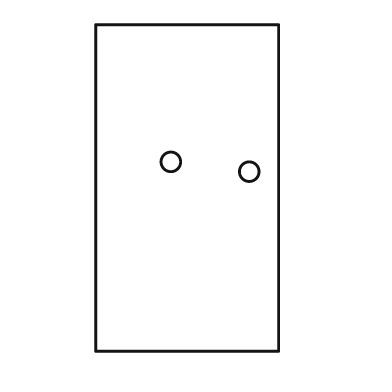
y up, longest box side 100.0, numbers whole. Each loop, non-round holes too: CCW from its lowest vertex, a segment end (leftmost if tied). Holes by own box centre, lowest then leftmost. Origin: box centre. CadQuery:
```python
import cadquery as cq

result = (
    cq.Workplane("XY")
    .moveTo(-28.0, -50.0)
    .lineTo(28.0, -50.0)
    .lineTo(28.0, 50.0)
    .lineTo(-28.0, 50.0)
    .close()
    .moveTo(19.0, 5.0)
    .circle(3.0)
    .moveTo(-5.0, 8.0)
    .circle(3.0)
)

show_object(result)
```